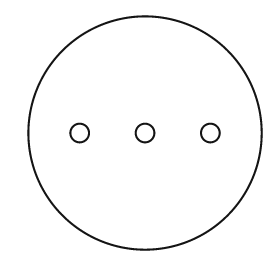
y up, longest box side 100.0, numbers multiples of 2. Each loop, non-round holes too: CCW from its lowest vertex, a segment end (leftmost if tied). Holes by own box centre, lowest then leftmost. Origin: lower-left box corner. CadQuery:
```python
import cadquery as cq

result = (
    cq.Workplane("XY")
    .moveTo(50.0, 50.0)
    .circle(50.0)
    .moveTo(22.0, 50.0)
    .circle(4.0)
    .moveTo(50.0, 50.0)
    .circle(4.0)
    .moveTo(78.0, 50.0)
    .circle(4.0)
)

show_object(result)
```